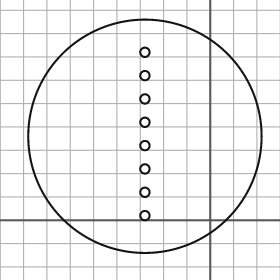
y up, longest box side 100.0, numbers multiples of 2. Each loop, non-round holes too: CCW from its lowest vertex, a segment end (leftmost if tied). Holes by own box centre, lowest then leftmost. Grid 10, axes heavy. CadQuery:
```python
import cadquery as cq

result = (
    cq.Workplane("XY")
    .moveTo(-28.0, 36.0)
    .circle(50.0)
    .moveTo(-28.0, 2.0)
    .circle(2.0)
    .moveTo(-28.0, 12.0)
    .circle(2.0)
    .moveTo(-28.0, 22.0)
    .circle(2.0)
    .moveTo(-28.0, 32.0)
    .circle(2.0)
    .moveTo(-28.0, 42.0)
    .circle(2.0)
    .moveTo(-28.0, 52.0)
    .circle(2.0)
    .moveTo(-28.0, 62.0)
    .circle(2.0)
    .moveTo(-28.0, 72.0)
    .circle(2.0)
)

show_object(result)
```